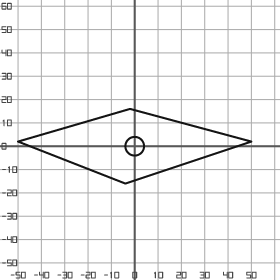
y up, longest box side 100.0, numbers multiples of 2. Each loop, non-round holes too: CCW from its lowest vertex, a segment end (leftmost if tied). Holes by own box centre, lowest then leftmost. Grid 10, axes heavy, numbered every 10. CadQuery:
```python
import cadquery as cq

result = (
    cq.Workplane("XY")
    .moveTo(-4.0, -16.0)
    .lineTo(50.0, 2.0)
    .lineTo(-2.0, 16.0)
    .lineTo(-50.0, 2.0)
    .close()
    .moveTo(0.0, 0.0)
    .circle(4.0)
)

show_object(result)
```